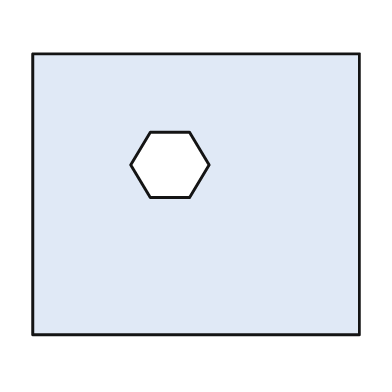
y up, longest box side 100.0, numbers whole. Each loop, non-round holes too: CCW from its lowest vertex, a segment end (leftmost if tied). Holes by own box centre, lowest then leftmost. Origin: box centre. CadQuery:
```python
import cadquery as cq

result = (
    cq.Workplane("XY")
    .moveTo(-50.0, -43.0)
    .lineTo(50.0, -43.0)
    .lineTo(50.0, 43.0)
    .lineTo(-50.0, 43.0)
    .close()
    .moveTo(-14.0, -1.0)
    .lineTo(-2.0, -1.0)
    .lineTo(4.0, 9.0)
    .lineTo(-2.0, 19.0)
    .lineTo(-14.0, 19.0)
    .lineTo(-20.0, 9.0)
    .close()
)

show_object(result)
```